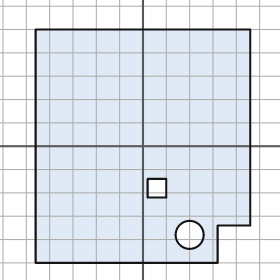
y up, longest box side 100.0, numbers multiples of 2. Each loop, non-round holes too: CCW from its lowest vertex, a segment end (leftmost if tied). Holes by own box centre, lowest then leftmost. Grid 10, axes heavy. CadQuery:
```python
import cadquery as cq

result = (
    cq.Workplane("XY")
    .moveTo(-46.0, -50.0)
    .lineTo(32.0, -50.0)
    .lineTo(32.0, -34.0)
    .lineTo(46.0, -34.0)
    .lineTo(46.0, 50.0)
    .lineTo(-46.0, 50.0)
    .close()
    .moveTo(20.0, -38.0)
    .circle(6.0)
    .moveTo(2.0, -22.0)
    .lineTo(10.0, -22.0)
    .lineTo(10.0, -14.0)
    .lineTo(2.0, -14.0)
    .close()
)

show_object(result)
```